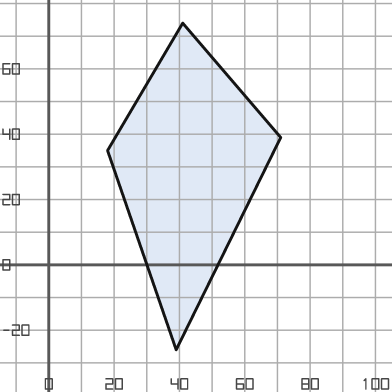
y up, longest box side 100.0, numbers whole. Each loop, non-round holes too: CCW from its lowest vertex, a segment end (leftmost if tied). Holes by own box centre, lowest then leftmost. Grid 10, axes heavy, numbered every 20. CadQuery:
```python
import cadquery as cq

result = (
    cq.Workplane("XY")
    .moveTo(39.0, -26.0)
    .lineTo(71.0, 39.0)
    .lineTo(41.0, 74.0)
    .lineTo(18.0, 35.0)
    .close()
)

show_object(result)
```